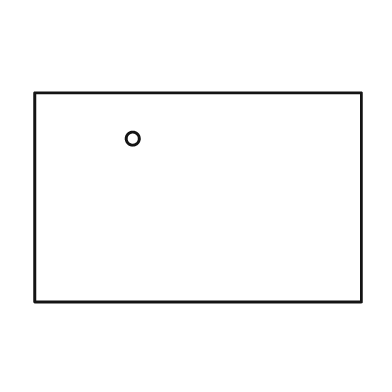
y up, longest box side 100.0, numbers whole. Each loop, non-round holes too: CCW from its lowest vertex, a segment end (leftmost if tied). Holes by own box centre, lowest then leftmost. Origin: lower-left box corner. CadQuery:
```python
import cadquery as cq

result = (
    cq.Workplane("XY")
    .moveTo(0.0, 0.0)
    .lineTo(100.0, 0.0)
    .lineTo(100.0, 64.0)
    .lineTo(0.0, 64.0)
    .close()
    .moveTo(30.0, 50.0)
    .circle(2.0)
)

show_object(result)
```